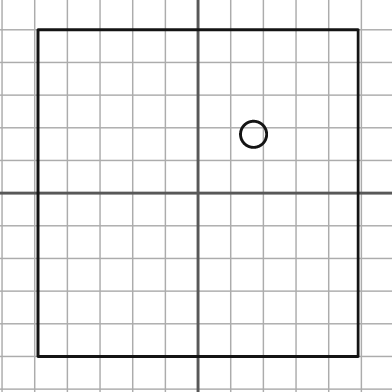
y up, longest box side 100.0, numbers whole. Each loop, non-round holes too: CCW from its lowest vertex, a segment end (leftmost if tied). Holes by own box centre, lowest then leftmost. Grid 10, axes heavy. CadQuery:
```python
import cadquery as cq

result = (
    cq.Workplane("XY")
    .moveTo(-49.0, -50.0)
    .lineTo(49.0, -50.0)
    .lineTo(49.0, 50.0)
    .lineTo(-49.0, 50.0)
    .close()
    .moveTo(17.0, 18.0)
    .circle(4.0)
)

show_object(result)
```